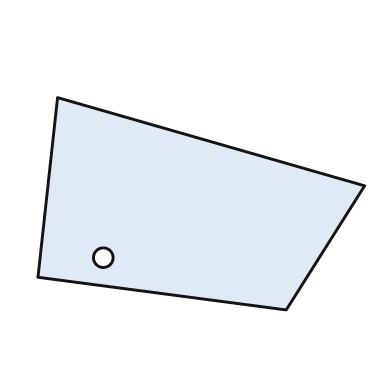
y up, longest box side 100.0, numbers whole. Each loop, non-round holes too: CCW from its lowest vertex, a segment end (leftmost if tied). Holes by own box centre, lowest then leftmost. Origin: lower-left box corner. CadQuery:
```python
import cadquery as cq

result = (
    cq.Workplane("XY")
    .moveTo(76.0, 0.0)
    .lineTo(100.0, 38.0)
    .lineTo(6.0, 65.0)
    .lineTo(0.0, 10.0)
    .close()
    .moveTo(20.0, 16.0)
    .circle(3.0)
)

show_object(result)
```